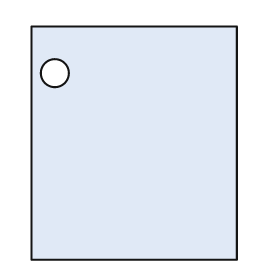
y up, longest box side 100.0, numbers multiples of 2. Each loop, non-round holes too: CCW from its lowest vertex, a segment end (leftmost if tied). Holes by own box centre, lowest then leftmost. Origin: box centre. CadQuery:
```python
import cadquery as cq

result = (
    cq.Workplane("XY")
    .moveTo(-44.0, -50.0)
    .lineTo(44.0, -50.0)
    .lineTo(44.0, 50.0)
    .lineTo(-44.0, 50.0)
    .close()
    .moveTo(-34.0, 30.0)
    .circle(6.0)
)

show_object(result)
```